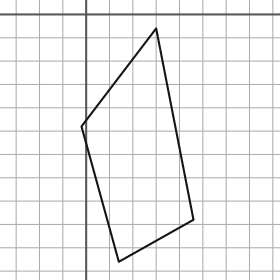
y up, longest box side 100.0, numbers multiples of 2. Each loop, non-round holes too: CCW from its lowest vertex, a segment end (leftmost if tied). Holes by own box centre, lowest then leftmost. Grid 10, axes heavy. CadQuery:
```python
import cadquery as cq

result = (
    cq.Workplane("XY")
    .moveTo(14.0, -106.0)
    .lineTo(46.0, -88.0)
    .lineTo(30.0, -6.0)
    .lineTo(-2.0, -48.0)
    .close()
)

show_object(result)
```